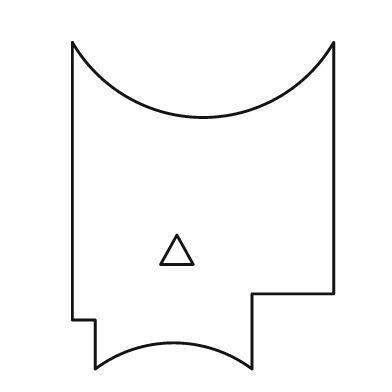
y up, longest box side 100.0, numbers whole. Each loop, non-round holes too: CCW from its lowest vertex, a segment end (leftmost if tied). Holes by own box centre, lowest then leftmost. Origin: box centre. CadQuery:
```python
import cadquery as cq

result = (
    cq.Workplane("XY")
    .moveTo(-33.0, -50.0)
    .threePointArc((-9.0, -42.0), (15.0, -50.0))
    .lineTo(15.0, -27.0)
    .lineTo(40.0, -27.0)
    .lineTo(40.0, 50.0)
    .threePointArc((0.0, 27.0), (-40.0, 50.0))
    .lineTo(-40.0, -35.0)
    .lineTo(-33.0, -35.0)
    .close()
    .moveTo(-13.0, -18.0)
    .lineTo(-3.0, -18.0)
    .lineTo(-8.0, -9.0)
    .close()
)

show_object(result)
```